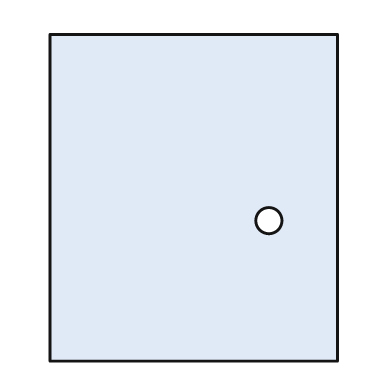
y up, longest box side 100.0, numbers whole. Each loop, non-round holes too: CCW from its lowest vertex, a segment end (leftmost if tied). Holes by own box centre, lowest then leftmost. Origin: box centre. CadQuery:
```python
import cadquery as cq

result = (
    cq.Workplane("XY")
    .moveTo(-44.0, -50.0)
    .lineTo(44.0, -50.0)
    .lineTo(44.0, 50.0)
    .lineTo(-44.0, 50.0)
    .close()
    .moveTo(23.0, -7.0)
    .circle(4.0)
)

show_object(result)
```